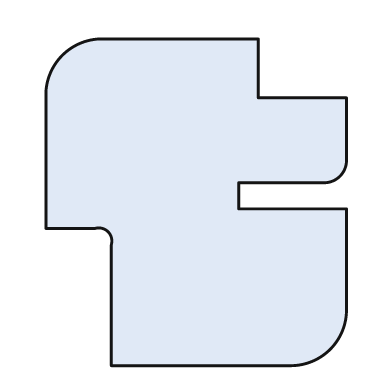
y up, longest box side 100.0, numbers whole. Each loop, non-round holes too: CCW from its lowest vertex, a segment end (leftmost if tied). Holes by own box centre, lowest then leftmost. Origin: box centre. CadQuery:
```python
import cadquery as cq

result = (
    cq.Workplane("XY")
    .moveTo(-26.0, -50.0)
    .lineTo(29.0, -50.0)
    .threePointArc((41.0, -45.0), (46.0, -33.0))
    .lineTo(46.0, -2.0)
    .lineTo(13.0, -2.0)
    .lineTo(13.0, 6.0)
    .lineTo(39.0, 6.0)
    .threePointArc((44.0, 8.0), (46.0, 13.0))
    .lineTo(46.0, 32.0)
    .lineTo(19.0, 32.0)
    .lineTo(19.0, 50.0)
    .lineTo(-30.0, 50.0)
    .threePointArc((-41.0, 45.0), (-46.0, 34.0))
    .lineTo(-46.0, -8.0)
    .lineTo(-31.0, -8.0)
    .threePointArc((-27.0, -9.0), (-26.0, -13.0))
    .close()
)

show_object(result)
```